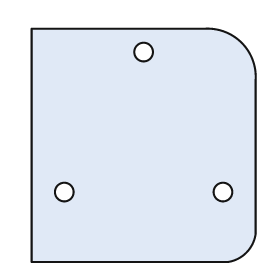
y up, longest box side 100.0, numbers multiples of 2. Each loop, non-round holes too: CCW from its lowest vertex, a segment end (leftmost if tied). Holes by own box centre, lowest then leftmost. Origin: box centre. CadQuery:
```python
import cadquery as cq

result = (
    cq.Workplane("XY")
    .moveTo(-48.0, -50.0)
    .lineTo(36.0, -50.0)
    .threePointArc((44.0, -46.0), (48.0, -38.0))
    .lineTo(48.0, 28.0)
    .threePointArc((42.0, 44.0), (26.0, 50.0))
    .lineTo(-48.0, 50.0)
    .close()
    .moveTo(-34.0, -20.0)
    .circle(4.0)
    .moveTo(34.0, -20.0)
    .circle(4.0)
    .moveTo(0.0, 40.0)
    .circle(4.0)
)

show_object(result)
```